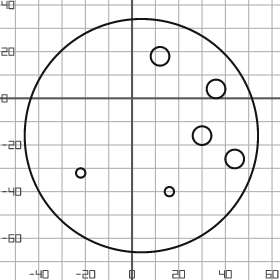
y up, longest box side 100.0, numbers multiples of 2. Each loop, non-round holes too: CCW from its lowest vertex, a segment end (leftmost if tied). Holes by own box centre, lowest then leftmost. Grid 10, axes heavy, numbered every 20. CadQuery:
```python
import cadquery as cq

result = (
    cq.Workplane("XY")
    .moveTo(4.0, -16.0)
    .circle(50.0)
    .moveTo(16.0, -40.0)
    .circle(2.0)
    .moveTo(-22.0, -32.0)
    .circle(2.0)
    .moveTo(44.0, -26.0)
    .circle(4.0)
    .moveTo(30.0, -16.0)
    .circle(4.0)
    .moveTo(36.0, 4.0)
    .circle(4.0)
    .moveTo(12.0, 18.0)
    .circle(4.0)
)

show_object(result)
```